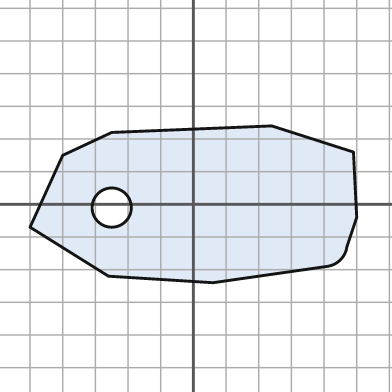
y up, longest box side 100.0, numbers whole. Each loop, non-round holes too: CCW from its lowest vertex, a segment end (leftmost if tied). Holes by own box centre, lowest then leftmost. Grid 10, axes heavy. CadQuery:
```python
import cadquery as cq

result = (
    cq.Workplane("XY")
    .moveTo(6.0, -24.0)
    .lineTo(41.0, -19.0)
    .threePointArc((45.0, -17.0), (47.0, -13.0))
    .lineTo(50.0, -4.0)
    .lineTo(49.0, 16.0)
    .lineTo(24.0, 24.0)
    .lineTo(-25.0, 22.0)
    .lineTo(-40.0, 15.0)
    .lineTo(-50.0, -7.0)
    .lineTo(-26.0, -22.0)
    .close()
    .moveTo(-25.0, -1.0)
    .circle(6.0)
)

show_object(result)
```